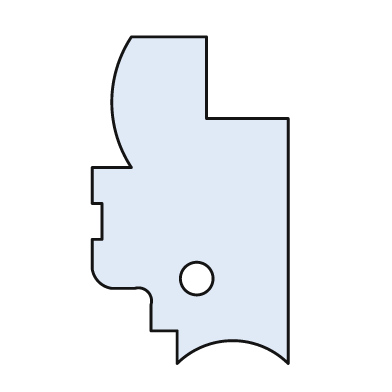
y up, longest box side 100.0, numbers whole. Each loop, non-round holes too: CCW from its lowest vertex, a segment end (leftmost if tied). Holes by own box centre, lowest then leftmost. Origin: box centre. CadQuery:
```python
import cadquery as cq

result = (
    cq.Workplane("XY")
    .moveTo(-4.0, -50.0)
    .threePointArc((13.0, -43.0), (30.0, -50.0))
    .lineTo(30.0, 25.0)
    .lineTo(5.0, 25.0)
    .lineTo(5.0, 50.0)
    .lineTo(-18.0, 50.0)
    .threePointArc((-24.0, 30.0), (-18.0, 10.0))
    .lineTo(-30.0, 10.0)
    .lineTo(-30.0, -1.0)
    .lineTo(-27.0, -1.0)
    .lineTo(-27.0, -12.0)
    .lineTo(-30.0, -12.0)
    .lineTo(-30.0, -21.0)
    .threePointArc((-28.0, -25.0), (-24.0, -27.0))
    .lineTo(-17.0, -27.0)
    .threePointArc((-13.0, -28.0), (-12.0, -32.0))
    .lineTo(-12.0, -40.0)
    .lineTo(-4.0, -40.0)
    .close()
    .moveTo(2.0, -24.0)
    .circle(5.0)
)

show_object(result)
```